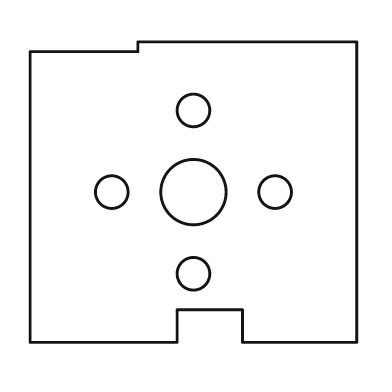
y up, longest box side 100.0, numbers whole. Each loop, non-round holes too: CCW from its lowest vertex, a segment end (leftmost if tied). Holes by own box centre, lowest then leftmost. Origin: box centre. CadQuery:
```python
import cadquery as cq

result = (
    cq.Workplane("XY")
    .moveTo(-50.0, -46.0)
    .lineTo(-5.0, -46.0)
    .lineTo(-5.0, -36.0)
    .lineTo(15.0, -36.0)
    .lineTo(15.0, -46.0)
    .lineTo(50.0, -46.0)
    .lineTo(50.0, 46.0)
    .lineTo(-17.0, 46.0)
    .lineTo(-17.0, 43.0)
    .lineTo(-50.0, 43.0)
    .close()
    .moveTo(0.0, -25.0)
    .circle(5.0)
    .moveTo(-25.0, 0.0)
    .circle(5.0)
    .moveTo(0.0, 0.0)
    .circle(10.0)
    .moveTo(25.0, 0.0)
    .circle(5.0)
    .moveTo(0.0, 25.0)
    .circle(5.0)
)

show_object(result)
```